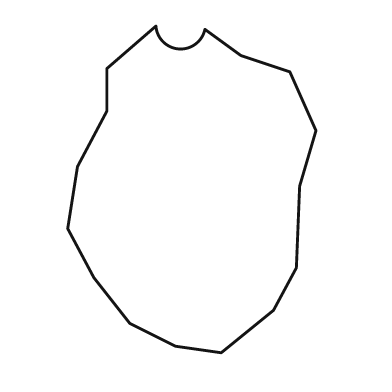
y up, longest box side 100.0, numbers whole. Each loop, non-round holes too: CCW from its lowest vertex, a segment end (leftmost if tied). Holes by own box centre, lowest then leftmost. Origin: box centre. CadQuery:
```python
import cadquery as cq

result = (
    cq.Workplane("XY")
    .moveTo(9.0, -50.0)
    .lineTo(25.0, -37.0)
    .lineTo(32.0, -24.0)
    .lineTo(33.0, 1.0)
    .lineTo(38.0, 18.0)
    .lineTo(30.0, 36.0)
    .lineTo(15.0, 41.0)
    .lineTo(4.0, 49.0)
    .threePointArc((-4.0, 43.0), (-11.0, 50.0))
    .lineTo(-26.0, 37.0)
    .lineTo(-26.0, 24.0)
    .lineTo(-35.0, 7.0)
    .lineTo(-38.0, -12.0)
    .lineTo(-30.0, -27.0)
    .lineTo(-19.0, -41.0)
    .lineTo(-5.0, -48.0)
    .close()
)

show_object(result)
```